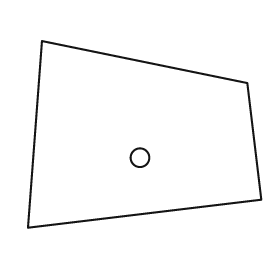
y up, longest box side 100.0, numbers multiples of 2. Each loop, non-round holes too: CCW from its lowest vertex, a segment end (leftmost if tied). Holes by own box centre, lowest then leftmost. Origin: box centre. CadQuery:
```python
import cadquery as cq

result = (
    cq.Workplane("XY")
    .moveTo(-50.0, -40.0)
    .lineTo(50.0, -28.0)
    .lineTo(44.0, 22.0)
    .lineTo(-44.0, 40.0)
    .close()
    .moveTo(-2.0, -10.0)
    .circle(4.0)
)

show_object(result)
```